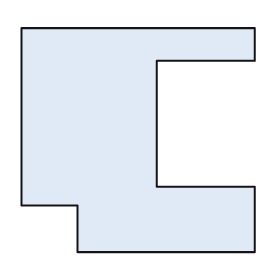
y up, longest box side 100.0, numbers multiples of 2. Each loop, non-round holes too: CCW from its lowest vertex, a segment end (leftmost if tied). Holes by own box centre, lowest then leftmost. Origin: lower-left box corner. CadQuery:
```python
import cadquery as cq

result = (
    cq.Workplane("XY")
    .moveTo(24.0, 0.0)
    .lineTo(100.0, 0.0)
    .lineTo(100.0, 28.0)
    .lineTo(58.0, 28.0)
    .lineTo(58.0, 82.0)
    .lineTo(100.0, 82.0)
    .lineTo(100.0, 96.0)
    .lineTo(0.0, 96.0)
    .lineTo(0.0, 20.0)
    .lineTo(24.0, 20.0)
    .close()
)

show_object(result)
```